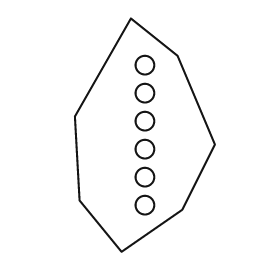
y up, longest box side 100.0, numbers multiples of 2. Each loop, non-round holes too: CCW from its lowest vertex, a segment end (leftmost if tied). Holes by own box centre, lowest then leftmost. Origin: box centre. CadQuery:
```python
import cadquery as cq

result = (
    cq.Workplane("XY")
    .moveTo(-10.0, -50.0)
    .lineTo(16.0, -32.0)
    .lineTo(30.0, -4.0)
    .lineTo(14.0, 34.0)
    .lineTo(-6.0, 50.0)
    .lineTo(-30.0, 8.0)
    .lineTo(-28.0, -28.0)
    .close()
    .moveTo(0.0, -30.0)
    .circle(4.0)
    .moveTo(0.0, -18.0)
    .circle(4.0)
    .moveTo(0.0, -6.0)
    .circle(4.0)
    .moveTo(0.0, 6.0)
    .circle(4.0)
    .moveTo(0.0, 18.0)
    .circle(4.0)
    .moveTo(0.0, 30.0)
    .circle(4.0)
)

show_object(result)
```